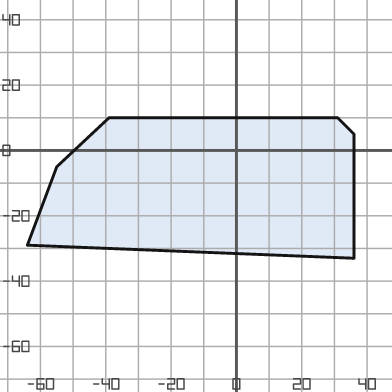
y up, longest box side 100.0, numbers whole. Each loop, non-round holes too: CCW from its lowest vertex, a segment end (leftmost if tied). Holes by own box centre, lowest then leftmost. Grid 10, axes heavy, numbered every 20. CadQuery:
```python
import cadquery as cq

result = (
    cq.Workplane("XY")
    .moveTo(36.0, -33.0)
    .lineTo(36.0, 5.0)
    .lineTo(31.0, 10.0)
    .lineTo(-39.0, 10.0)
    .lineTo(-55.0, -5.0)
    .lineTo(-64.0, -29.0)
    .close()
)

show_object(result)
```